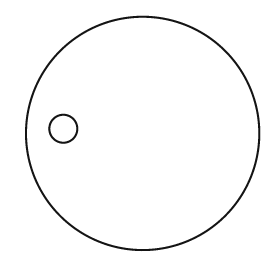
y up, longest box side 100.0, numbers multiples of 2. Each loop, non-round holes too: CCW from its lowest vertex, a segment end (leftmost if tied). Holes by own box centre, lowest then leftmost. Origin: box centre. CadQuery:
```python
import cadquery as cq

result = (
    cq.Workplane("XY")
    .moveTo(0.0, 0.0)
    .circle(50.0)
    .moveTo(-34.0, 2.0)
    .circle(6.0)
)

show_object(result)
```